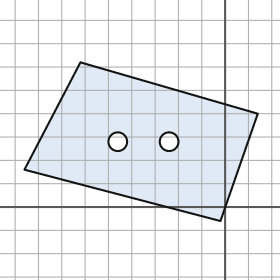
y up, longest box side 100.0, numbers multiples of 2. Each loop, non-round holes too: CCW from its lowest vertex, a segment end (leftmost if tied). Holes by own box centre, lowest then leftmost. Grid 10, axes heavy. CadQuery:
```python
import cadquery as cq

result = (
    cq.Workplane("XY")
    .moveTo(-2.0, -6.0)
    .lineTo(14.0, 40.0)
    .lineTo(-62.0, 62.0)
    .lineTo(-86.0, 16.0)
    .close()
    .moveTo(-46.0, 28.0)
    .circle(4.0)
    .moveTo(-24.0, 28.0)
    .circle(4.0)
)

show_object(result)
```